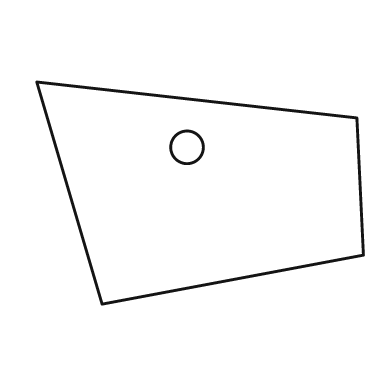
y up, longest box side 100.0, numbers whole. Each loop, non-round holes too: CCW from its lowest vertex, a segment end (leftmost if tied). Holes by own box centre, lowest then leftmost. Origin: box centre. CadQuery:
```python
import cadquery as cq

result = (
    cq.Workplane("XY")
    .moveTo(-30.0, -34.0)
    .lineTo(50.0, -19.0)
    .lineTo(48.0, 23.0)
    .lineTo(-50.0, 34.0)
    .close()
    .moveTo(-4.0, 14.0)
    .circle(5.0)
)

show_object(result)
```